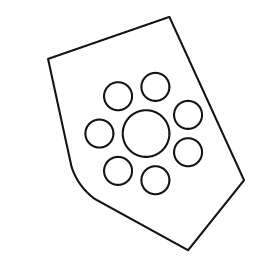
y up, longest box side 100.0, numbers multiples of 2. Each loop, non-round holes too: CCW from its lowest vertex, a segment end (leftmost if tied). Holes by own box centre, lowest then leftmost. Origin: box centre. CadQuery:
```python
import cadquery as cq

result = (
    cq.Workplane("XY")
    .moveTo(18.0, -50.0)
    .lineTo(42.0, -20.0)
    .lineTo(10.0, 50.0)
    .lineTo(-42.0, 32.0)
    .lineTo(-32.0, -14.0)
    .threePointArc((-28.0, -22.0), (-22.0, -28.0))
    .close()
    .moveTo(4.0, -20.0)
    .circle(6.0)
    .moveTo(-12.0, -16.0)
    .circle(6.0)
    .moveTo(18.0, -8.0)
    .circle(6.0)
    .moveTo(-20.0, 0.0)
    .circle(6.0)
    .moveTo(0.0, 0.0)
    .circle(10.0)
    .moveTo(18.0, 8.0)
    .circle(6.0)
    .moveTo(-12.0, 16.0)
    .circle(6.0)
    .moveTo(4.0, 20.0)
    .circle(6.0)
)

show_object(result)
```